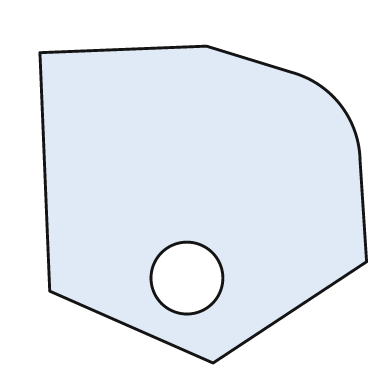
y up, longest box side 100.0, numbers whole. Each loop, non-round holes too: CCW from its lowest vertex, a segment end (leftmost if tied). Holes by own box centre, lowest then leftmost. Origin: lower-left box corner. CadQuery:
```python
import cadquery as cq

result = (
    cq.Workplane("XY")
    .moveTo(53.0, 0.0)
    .lineTo(100.0, 31.0)
    .lineTo(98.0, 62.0)
    .threePointArc((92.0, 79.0), (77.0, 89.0))
    .lineTo(51.0, 97.0)
    .lineTo(0.0, 95.0)
    .lineTo(3.0, 22.0)
    .close()
    .moveTo(45.0, 26.0)
    .circle(11.0)
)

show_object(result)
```